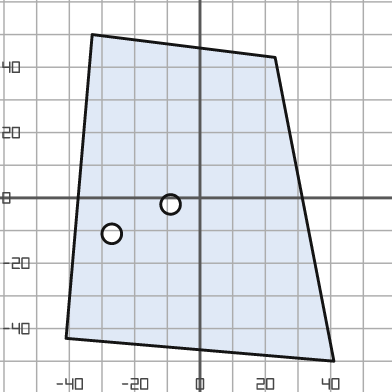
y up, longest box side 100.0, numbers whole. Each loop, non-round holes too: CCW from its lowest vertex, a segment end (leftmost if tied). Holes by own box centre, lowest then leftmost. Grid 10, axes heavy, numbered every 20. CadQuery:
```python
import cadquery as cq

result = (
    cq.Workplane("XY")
    .moveTo(41.0, -50.0)
    .lineTo(23.0, 43.0)
    .lineTo(-33.0, 50.0)
    .lineTo(-41.0, -43.0)
    .close()
    .moveTo(-27.0, -11.0)
    .circle(3.0)
    .moveTo(-9.0, -2.0)
    .circle(3.0)
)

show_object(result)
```